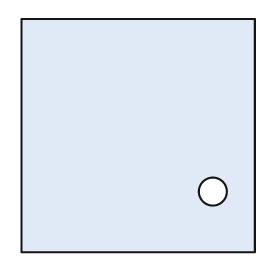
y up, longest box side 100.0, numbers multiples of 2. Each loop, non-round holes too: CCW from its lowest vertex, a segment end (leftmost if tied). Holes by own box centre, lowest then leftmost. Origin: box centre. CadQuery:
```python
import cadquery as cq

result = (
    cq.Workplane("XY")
    .moveTo(-50.0, -50.0)
    .lineTo(50.0, -50.0)
    .lineTo(50.0, 50.0)
    .lineTo(-50.0, 50.0)
    .close()
    .moveTo(32.0, -24.0)
    .circle(6.0)
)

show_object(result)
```